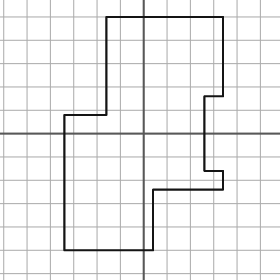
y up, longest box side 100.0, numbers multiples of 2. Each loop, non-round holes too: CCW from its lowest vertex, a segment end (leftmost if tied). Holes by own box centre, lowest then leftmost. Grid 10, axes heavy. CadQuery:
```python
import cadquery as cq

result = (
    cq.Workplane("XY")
    .moveTo(-34.0, -50.0)
    .lineTo(4.0, -50.0)
    .lineTo(4.0, -24.0)
    .lineTo(34.0, -24.0)
    .lineTo(34.0, -16.0)
    .lineTo(26.0, -16.0)
    .lineTo(26.0, 16.0)
    .lineTo(34.0, 16.0)
    .lineTo(34.0, 50.0)
    .lineTo(-16.0, 50.0)
    .lineTo(-16.0, 8.0)
    .lineTo(-34.0, 8.0)
    .close()
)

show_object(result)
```